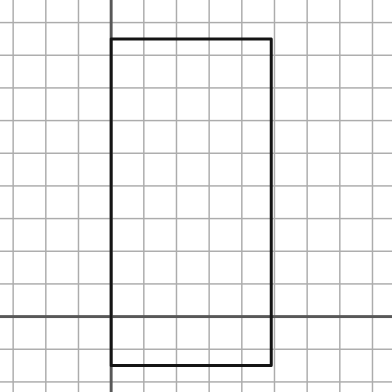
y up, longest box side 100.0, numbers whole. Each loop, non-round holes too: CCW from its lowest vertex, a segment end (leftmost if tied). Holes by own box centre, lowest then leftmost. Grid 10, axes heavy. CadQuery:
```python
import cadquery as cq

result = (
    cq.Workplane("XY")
    .moveTo(0.0, -15.0)
    .lineTo(49.0, -15.0)
    .lineTo(49.0, 85.0)
    .lineTo(0.0, 85.0)
    .close()
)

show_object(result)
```